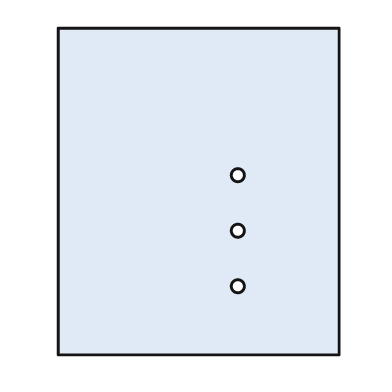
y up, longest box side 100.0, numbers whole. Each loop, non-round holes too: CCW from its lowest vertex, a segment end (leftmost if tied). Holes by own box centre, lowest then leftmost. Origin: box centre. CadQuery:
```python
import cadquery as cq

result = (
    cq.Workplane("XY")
    .moveTo(-43.0, -50.0)
    .lineTo(43.0, -50.0)
    .lineTo(43.0, 50.0)
    .lineTo(-43.0, 50.0)
    .close()
    .moveTo(12.0, -29.0)
    .circle(2.0)
    .moveTo(12.0, -12.0)
    .circle(2.0)
    .moveTo(12.0, 5.0)
    .circle(2.0)
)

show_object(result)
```